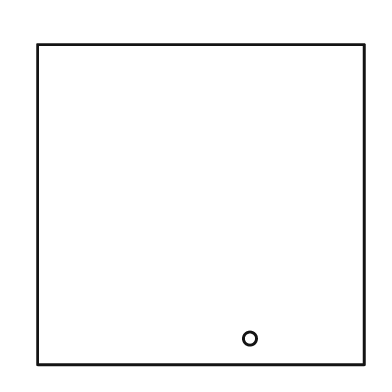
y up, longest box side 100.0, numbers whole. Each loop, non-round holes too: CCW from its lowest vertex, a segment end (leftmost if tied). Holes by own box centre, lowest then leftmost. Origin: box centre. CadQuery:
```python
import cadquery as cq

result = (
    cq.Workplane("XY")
    .moveTo(-50.0, -49.0)
    .lineTo(50.0, -49.0)
    .lineTo(50.0, 49.0)
    .lineTo(-50.0, 49.0)
    .close()
    .moveTo(15.0, -41.0)
    .circle(2.0)
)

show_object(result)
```